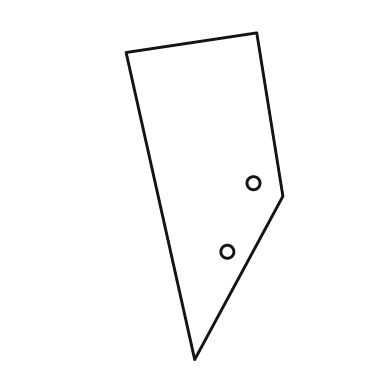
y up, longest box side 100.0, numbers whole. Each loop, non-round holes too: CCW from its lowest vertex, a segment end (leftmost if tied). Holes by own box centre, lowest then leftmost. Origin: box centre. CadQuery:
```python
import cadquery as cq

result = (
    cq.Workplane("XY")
    .moveTo(-3.0, -50.0)
    .lineTo(24.0, 0.0)
    .lineTo(16.0, 50.0)
    .lineTo(-24.0, 44.0)
    .close()
    .moveTo(7.0, -17.0)
    .circle(2.0)
    .moveTo(15.0, 4.0)
    .circle(2.0)
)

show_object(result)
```